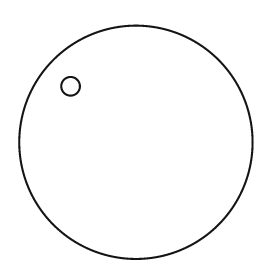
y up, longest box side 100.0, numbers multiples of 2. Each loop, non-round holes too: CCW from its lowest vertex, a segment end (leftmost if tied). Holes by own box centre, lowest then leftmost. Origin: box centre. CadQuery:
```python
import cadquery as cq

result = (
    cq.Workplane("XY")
    .moveTo(0.0, 0.0)
    .circle(50.0)
    .moveTo(-28.0, 24.0)
    .circle(4.0)
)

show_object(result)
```